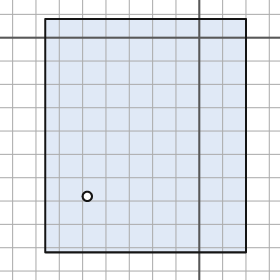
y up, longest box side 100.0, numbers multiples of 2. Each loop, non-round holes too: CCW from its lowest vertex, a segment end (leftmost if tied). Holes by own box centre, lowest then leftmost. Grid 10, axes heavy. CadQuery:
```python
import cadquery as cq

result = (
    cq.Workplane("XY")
    .moveTo(-66.0, -92.0)
    .lineTo(20.0, -92.0)
    .lineTo(20.0, 8.0)
    .lineTo(-66.0, 8.0)
    .close()
    .moveTo(-48.0, -68.0)
    .circle(2.0)
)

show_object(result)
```